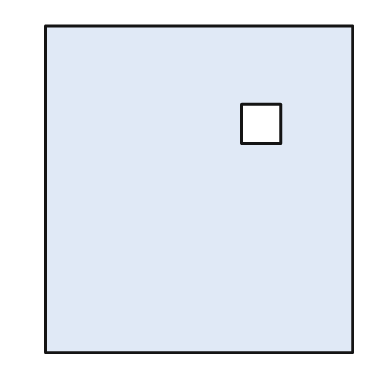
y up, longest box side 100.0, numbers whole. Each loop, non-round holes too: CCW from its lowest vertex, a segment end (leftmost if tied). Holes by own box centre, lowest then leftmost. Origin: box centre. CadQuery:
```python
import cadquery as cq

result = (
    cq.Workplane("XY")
    .moveTo(-47.0, -50.0)
    .lineTo(47.0, -50.0)
    .lineTo(47.0, 50.0)
    .lineTo(-47.0, 50.0)
    .close()
    .moveTo(13.0, 14.0)
    .lineTo(25.0, 14.0)
    .lineTo(25.0, 26.0)
    .lineTo(13.0, 26.0)
    .close()
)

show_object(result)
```